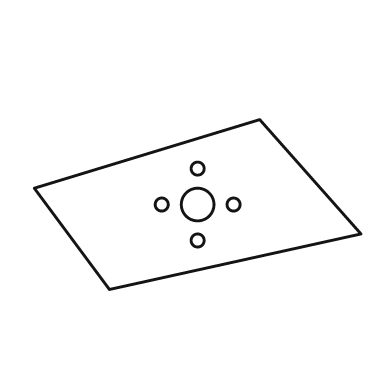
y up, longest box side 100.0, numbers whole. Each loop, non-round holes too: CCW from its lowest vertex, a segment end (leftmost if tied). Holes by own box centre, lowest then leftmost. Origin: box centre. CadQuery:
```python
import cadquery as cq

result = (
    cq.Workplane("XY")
    .moveTo(-27.0, -26.0)
    .lineTo(50.0, -9.0)
    .lineTo(19.0, 26.0)
    .lineTo(-50.0, 5.0)
    .close()
    .moveTo(0.0, -11.0)
    .circle(2.0)
    .moveTo(-11.0, 0.0)
    .circle(2.0)
    .moveTo(0.0, 0.0)
    .circle(5.0)
    .moveTo(11.0, 0.0)
    .circle(2.0)
    .moveTo(0.0, 11.0)
    .circle(2.0)
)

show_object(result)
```